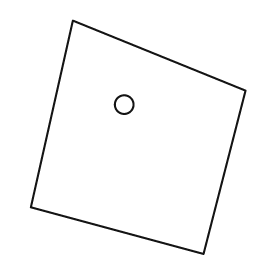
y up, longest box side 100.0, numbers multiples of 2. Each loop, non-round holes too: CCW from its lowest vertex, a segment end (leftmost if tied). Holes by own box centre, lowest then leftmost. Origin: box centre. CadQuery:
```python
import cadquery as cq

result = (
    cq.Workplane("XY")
    .moveTo(28.0, -50.0)
    .lineTo(46.0, 20.0)
    .lineTo(-28.0, 50.0)
    .lineTo(-46.0, -30.0)
    .close()
    .moveTo(-6.0, 14.0)
    .circle(4.0)
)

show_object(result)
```